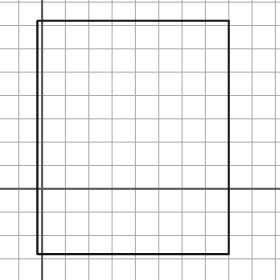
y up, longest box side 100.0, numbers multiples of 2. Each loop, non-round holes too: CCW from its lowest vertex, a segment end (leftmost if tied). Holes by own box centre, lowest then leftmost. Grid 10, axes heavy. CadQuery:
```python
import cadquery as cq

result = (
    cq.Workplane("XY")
    .moveTo(-2.0, -28.0)
    .lineTo(80.0, -28.0)
    .lineTo(80.0, 72.0)
    .lineTo(-2.0, 72.0)
    .close()
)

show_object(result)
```